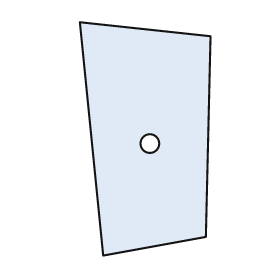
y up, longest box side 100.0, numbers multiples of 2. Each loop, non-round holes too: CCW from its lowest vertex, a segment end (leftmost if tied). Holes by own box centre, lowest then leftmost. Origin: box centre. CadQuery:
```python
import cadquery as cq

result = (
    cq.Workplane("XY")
    .moveTo(-18.0, -50.0)
    .lineTo(26.0, -42.0)
    .lineTo(28.0, 44.0)
    .lineTo(-28.0, 50.0)
    .close()
    .moveTo(2.0, -2.0)
    .circle(4.0)
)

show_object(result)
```